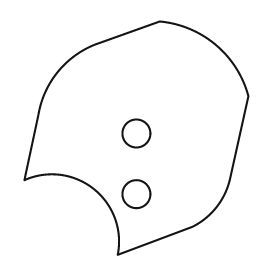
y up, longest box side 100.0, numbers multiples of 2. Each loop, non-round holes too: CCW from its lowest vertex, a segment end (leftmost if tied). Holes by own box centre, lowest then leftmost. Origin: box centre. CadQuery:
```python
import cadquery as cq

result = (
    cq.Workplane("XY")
    .moveTo(-8.0, -50.0)
    .lineTo(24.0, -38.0)
    .threePointArc((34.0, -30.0), (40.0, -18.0))
    .lineTo(48.0, 18.0)
    .threePointArc((34.0, 40.0), (10.0, 50.0))
    .lineTo(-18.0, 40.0)
    .threePointArc((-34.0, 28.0), (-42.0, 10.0))
    .lineTo(-48.0, -18.0)
    .threePointArc((-18.0, -22.0), (-8.0, -50.0))
    .close()
    .moveTo(0.0, -24.0)
    .circle(6.0)
    .moveTo(0.0, 2.0)
    .circle(6.0)
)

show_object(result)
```